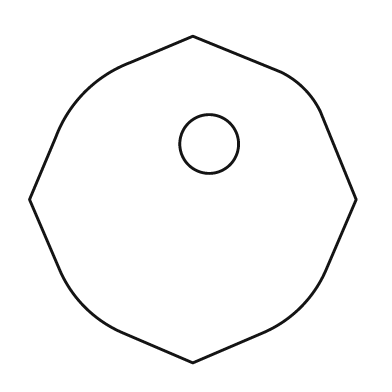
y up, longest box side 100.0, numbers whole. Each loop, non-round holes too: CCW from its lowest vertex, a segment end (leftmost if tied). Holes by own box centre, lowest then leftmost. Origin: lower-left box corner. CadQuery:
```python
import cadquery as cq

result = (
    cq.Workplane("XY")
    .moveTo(50.0, 0.0)
    .lineTo(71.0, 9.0)
    .threePointArc((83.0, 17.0), (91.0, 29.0))
    .lineTo(100.0, 50.0)
    .lineTo(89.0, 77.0)
    .threePointArc((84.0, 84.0), (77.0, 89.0))
    .lineTo(50.0, 100.0)
    .lineTo(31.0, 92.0)
    .threePointArc((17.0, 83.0), (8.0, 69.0))
    .lineTo(0.0, 50.0)
    .lineTo(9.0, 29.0)
    .threePointArc((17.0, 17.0), (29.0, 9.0))
    .close()
    .moveTo(55.0, 67.0)
    .circle(9.0)
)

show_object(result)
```